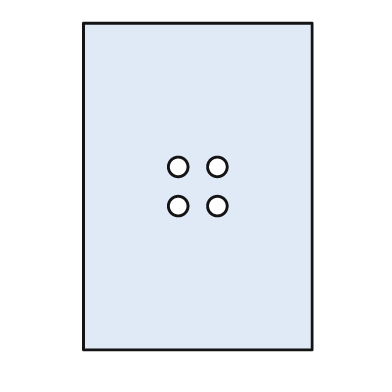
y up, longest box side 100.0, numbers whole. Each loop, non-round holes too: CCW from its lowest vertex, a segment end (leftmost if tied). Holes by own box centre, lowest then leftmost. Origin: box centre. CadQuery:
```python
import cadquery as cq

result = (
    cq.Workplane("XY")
    .moveTo(-35.0, -50.0)
    .lineTo(35.0, -50.0)
    .lineTo(35.0, 50.0)
    .lineTo(-35.0, 50.0)
    .close()
    .moveTo(-6.0, -6.0)
    .circle(3.0)
    .moveTo(6.0, -6.0)
    .circle(3.0)
    .moveTo(-6.0, 6.0)
    .circle(3.0)
    .moveTo(6.0, 6.0)
    .circle(3.0)
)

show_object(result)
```